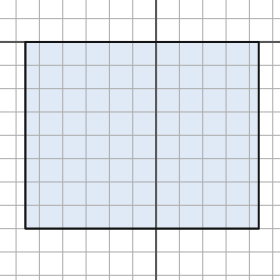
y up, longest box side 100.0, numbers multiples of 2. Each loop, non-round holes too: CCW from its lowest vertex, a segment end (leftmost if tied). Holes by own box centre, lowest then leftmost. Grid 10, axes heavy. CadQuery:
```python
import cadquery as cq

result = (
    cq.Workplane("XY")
    .moveTo(-56.0, -80.0)
    .lineTo(44.0, -80.0)
    .lineTo(44.0, 0.0)
    .lineTo(-56.0, 0.0)
    .close()
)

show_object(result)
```